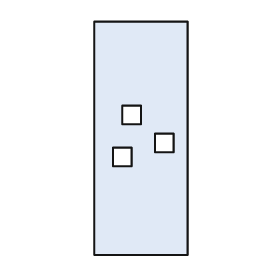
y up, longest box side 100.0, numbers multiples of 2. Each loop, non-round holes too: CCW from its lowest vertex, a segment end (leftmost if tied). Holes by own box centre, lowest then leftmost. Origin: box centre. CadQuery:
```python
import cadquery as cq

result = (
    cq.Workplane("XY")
    .moveTo(-20.0, -50.0)
    .lineTo(20.0, -50.0)
    .lineTo(20.0, 50.0)
    .lineTo(-20.0, 50.0)
    .close()
    .moveTo(-12.0, -12.0)
    .lineTo(-4.0, -12.0)
    .lineTo(-4.0, -4.0)
    .lineTo(-12.0, -4.0)
    .close()
    .moveTo(6.0, -6.0)
    .lineTo(14.0, -6.0)
    .lineTo(14.0, 2.0)
    .lineTo(6.0, 2.0)
    .close()
    .moveTo(-8.0, 6.0)
    .lineTo(0.0, 6.0)
    .lineTo(0.0, 14.0)
    .lineTo(-8.0, 14.0)
    .close()
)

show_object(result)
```